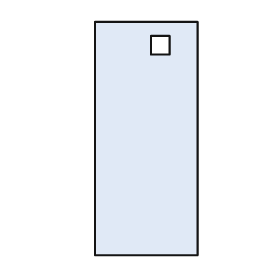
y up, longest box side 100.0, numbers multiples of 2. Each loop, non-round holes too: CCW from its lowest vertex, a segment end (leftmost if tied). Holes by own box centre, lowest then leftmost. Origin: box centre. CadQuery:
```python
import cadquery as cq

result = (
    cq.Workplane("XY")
    .moveTo(-22.0, -50.0)
    .lineTo(22.0, -50.0)
    .lineTo(22.0, 50.0)
    .lineTo(-22.0, 50.0)
    .close()
    .moveTo(2.0, 36.0)
    .lineTo(10.0, 36.0)
    .lineTo(10.0, 44.0)
    .lineTo(2.0, 44.0)
    .close()
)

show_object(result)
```